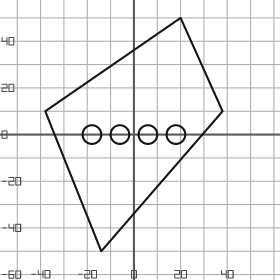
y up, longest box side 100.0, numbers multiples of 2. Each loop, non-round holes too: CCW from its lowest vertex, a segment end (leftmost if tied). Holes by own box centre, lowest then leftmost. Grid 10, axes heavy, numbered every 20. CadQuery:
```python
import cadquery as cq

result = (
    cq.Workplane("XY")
    .moveTo(-14.0, -50.0)
    .lineTo(38.0, 10.0)
    .lineTo(20.0, 50.0)
    .lineTo(-38.0, 10.0)
    .close()
    .moveTo(-18.0, 0.0)
    .circle(4.0)
    .moveTo(-6.0, 0.0)
    .circle(4.0)
    .moveTo(6.0, 0.0)
    .circle(4.0)
    .moveTo(18.0, 0.0)
    .circle(4.0)
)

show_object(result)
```